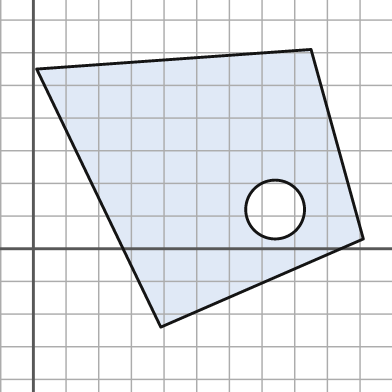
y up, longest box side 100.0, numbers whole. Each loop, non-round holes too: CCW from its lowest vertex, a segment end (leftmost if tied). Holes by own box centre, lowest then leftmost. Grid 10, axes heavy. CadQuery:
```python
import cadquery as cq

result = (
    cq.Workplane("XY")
    .moveTo(39.0, -24.0)
    .lineTo(101.0, 3.0)
    .lineTo(85.0, 61.0)
    .lineTo(1.0, 55.0)
    .close()
    .moveTo(74.0, 12.0)
    .circle(9.0)
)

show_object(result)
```